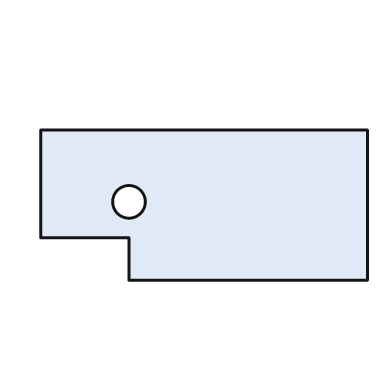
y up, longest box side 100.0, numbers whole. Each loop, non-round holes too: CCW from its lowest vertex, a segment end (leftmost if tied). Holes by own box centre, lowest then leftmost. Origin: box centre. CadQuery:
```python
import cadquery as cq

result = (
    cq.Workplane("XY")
    .moveTo(-23.0, -23.0)
    .lineTo(50.0, -23.0)
    .lineTo(50.0, 23.0)
    .lineTo(-50.0, 23.0)
    .lineTo(-50.0, -10.0)
    .lineTo(-23.0, -10.0)
    .close()
    .moveTo(-23.0, 1.0)
    .circle(5.0)
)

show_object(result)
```